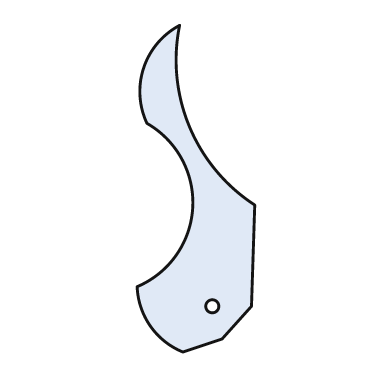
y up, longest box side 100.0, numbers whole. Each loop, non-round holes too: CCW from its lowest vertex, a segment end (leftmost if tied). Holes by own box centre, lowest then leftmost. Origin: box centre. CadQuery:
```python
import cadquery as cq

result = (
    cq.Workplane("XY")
    .moveTo(-4.0, -50.0)
    .lineTo(8.0, -46.0)
    .lineTo(17.0, -36.0)
    .lineTo(18.0, -5.0)
    .threePointArc((-2.0, 19.0), (-5.0, 50.0))
    .threePointArc((-16.0, 37.0), (-15.0, 20.0))
    .threePointArc((-1.0, -6.0), (-18.0, -30.0))
    .threePointArc((-14.0, -42.0), (-4.0, -50.0))
    .close()
    .moveTo(5.0, -36.0)
    .circle(2.0)
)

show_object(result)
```